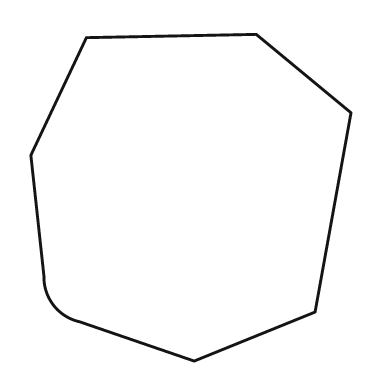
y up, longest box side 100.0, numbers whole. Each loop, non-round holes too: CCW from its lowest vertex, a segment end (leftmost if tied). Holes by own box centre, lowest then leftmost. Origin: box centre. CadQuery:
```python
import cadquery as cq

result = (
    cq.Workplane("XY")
    .moveTo(1.0, -50.0)
    .lineTo(38.0, -35.0)
    .lineTo(49.0, 26.0)
    .lineTo(20.0, 50.0)
    .lineTo(-32.0, 49.0)
    .lineTo(-49.0, 13.0)
    .lineTo(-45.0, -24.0)
    .threePointArc((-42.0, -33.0), (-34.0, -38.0))
    .close()
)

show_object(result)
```